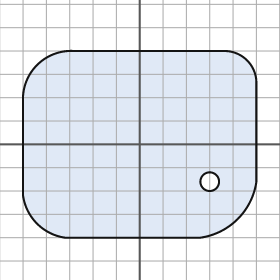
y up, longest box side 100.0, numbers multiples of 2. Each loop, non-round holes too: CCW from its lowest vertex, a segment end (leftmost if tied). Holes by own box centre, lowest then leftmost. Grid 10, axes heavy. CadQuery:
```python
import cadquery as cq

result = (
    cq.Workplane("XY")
    .moveTo(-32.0, -40.0)
    .lineTo(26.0, -40.0)
    .threePointArc((42.0, -32.0), (50.0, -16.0))
    .lineTo(50.0, 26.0)
    .threePointArc((46.0, 36.0), (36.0, 40.0))
    .lineTo(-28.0, 40.0)
    .threePointArc((-44.0, 34.0), (-50.0, 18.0))
    .lineTo(-50.0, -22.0)
    .threePointArc((-44.0, -34.0), (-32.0, -40.0))
    .close()
    .moveTo(30.0, -16.0)
    .circle(4.0)
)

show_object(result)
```